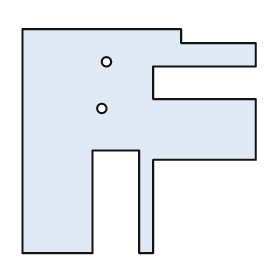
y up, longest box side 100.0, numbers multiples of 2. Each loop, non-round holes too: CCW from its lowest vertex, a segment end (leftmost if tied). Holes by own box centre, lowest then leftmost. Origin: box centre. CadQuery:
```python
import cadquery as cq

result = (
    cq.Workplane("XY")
    .moveTo(-50.0, -48.0)
    .lineTo(-20.0, -48.0)
    .lineTo(-20.0, -4.0)
    .lineTo(0.0, -4.0)
    .lineTo(0.0, -48.0)
    .lineTo(6.0, -48.0)
    .lineTo(6.0, -8.0)
    .lineTo(50.0, -8.0)
    .lineTo(50.0, 18.0)
    .lineTo(6.0, 18.0)
    .lineTo(6.0, 32.0)
    .lineTo(50.0, 32.0)
    .lineTo(50.0, 42.0)
    .lineTo(18.0, 42.0)
    .lineTo(18.0, 48.0)
    .lineTo(-50.0, 48.0)
    .close()
    .moveTo(-16.0, 14.0)
    .circle(2.0)
    .moveTo(-14.0, 34.0)
    .circle(2.0)
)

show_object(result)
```